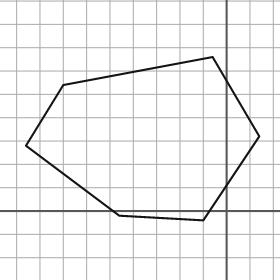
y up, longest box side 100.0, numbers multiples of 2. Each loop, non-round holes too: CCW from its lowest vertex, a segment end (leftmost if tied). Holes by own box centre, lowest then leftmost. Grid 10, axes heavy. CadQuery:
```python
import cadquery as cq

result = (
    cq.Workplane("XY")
    .moveTo(-10.0, -4.0)
    .lineTo(14.0, 32.0)
    .lineTo(-6.0, 66.0)
    .lineTo(-70.0, 54.0)
    .lineTo(-86.0, 28.0)
    .lineTo(-46.0, -2.0)
    .close()
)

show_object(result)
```